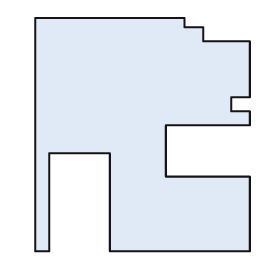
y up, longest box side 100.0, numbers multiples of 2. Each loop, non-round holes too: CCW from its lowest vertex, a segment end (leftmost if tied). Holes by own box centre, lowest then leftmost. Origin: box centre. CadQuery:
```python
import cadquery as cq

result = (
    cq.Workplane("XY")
    .moveTo(-46.0, -50.0)
    .lineTo(-40.0, -50.0)
    .lineTo(-40.0, -8.0)
    .lineTo(-14.0, -8.0)
    .lineTo(-14.0, -50.0)
    .lineTo(46.0, -50.0)
    .lineTo(46.0, -18.0)
    .lineTo(10.0, -18.0)
    .lineTo(10.0, 4.0)
    .lineTo(46.0, 4.0)
    .lineTo(46.0, 10.0)
    .lineTo(38.0, 10.0)
    .lineTo(38.0, 16.0)
    .lineTo(46.0, 16.0)
    .lineTo(46.0, 40.0)
    .lineTo(26.0, 40.0)
    .lineTo(26.0, 46.0)
    .lineTo(18.0, 46.0)
    .lineTo(18.0, 50.0)
    .lineTo(-46.0, 50.0)
    .close()
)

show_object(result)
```